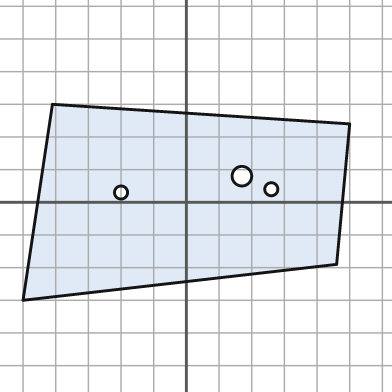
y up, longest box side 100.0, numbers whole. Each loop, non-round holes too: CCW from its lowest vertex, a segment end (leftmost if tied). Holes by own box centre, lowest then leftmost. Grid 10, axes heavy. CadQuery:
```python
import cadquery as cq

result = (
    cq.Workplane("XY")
    .moveTo(-50.0, -30.0)
    .lineTo(46.0, -19.0)
    .lineTo(50.0, 24.0)
    .lineTo(-41.0, 30.0)
    .close()
    .moveTo(-20.0, 3.0)
    .circle(2.0)
    .moveTo(26.0, 4.0)
    .circle(2.0)
    .moveTo(17.0, 8.0)
    .circle(3.0)
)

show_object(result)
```